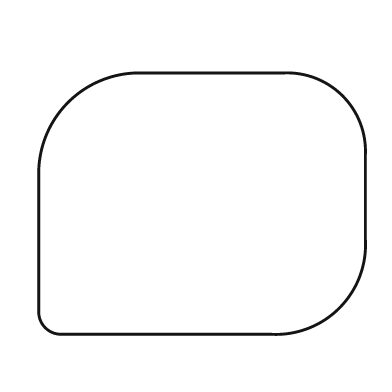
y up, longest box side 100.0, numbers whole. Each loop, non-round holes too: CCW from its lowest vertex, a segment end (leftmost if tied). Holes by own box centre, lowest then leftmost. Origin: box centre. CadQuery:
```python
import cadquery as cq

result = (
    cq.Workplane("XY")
    .moveTo(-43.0, -40.0)
    .lineTo(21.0, -40.0)
    .threePointArc((42.0, -32.0), (50.0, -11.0))
    .lineTo(50.0, 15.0)
    .threePointArc((43.0, 33.0), (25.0, 40.0))
    .lineTo(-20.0, 40.0)
    .threePointArc((-41.0, 31.0), (-50.0, 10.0))
    .lineTo(-50.0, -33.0)
    .threePointArc((-48.0, -38.0), (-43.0, -40.0))
    .close()
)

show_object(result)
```